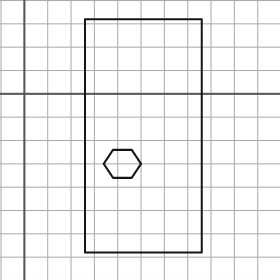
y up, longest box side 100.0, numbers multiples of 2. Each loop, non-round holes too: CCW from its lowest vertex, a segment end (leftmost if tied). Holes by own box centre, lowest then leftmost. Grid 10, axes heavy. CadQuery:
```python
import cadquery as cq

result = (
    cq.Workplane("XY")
    .moveTo(26.0, -68.0)
    .lineTo(76.0, -68.0)
    .lineTo(76.0, 32.0)
    .lineTo(26.0, 32.0)
    .close()
    .moveTo(38.0, -36.0)
    .lineTo(46.0, -36.0)
    .lineTo(50.0, -30.0)
    .lineTo(46.0, -24.0)
    .lineTo(38.0, -24.0)
    .lineTo(34.0, -30.0)
    .close()
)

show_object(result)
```